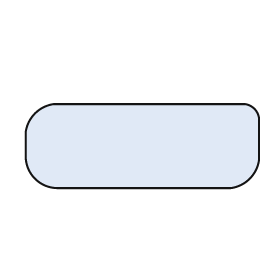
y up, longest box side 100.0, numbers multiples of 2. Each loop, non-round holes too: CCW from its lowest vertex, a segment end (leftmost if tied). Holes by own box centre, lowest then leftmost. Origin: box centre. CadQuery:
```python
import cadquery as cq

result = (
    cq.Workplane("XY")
    .moveTo(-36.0, -18.0)
    .lineTo(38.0, -18.0)
    .threePointArc((46.0, -14.0), (50.0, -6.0))
    .lineTo(50.0, 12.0)
    .threePointArc((48.0, 16.0), (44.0, 18.0))
    .lineTo(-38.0, 18.0)
    .threePointArc((-46.0, 14.0), (-50.0, 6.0))
    .lineTo(-50.0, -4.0)
    .threePointArc((-46.0, -14.0), (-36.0, -18.0))
    .close()
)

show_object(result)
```